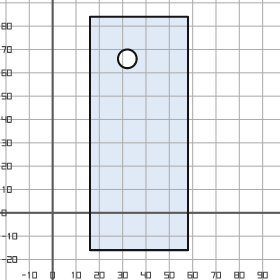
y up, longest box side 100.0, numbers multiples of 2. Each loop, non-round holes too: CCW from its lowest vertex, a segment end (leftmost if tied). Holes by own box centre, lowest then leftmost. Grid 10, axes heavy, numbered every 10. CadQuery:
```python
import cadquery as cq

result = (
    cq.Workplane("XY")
    .moveTo(16.0, -16.0)
    .lineTo(58.0, -16.0)
    .lineTo(58.0, 84.0)
    .lineTo(16.0, 84.0)
    .close()
    .moveTo(32.0, 66.0)
    .circle(4.0)
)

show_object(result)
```